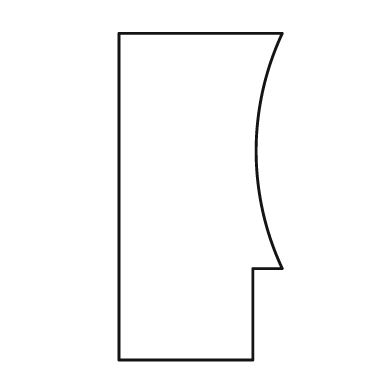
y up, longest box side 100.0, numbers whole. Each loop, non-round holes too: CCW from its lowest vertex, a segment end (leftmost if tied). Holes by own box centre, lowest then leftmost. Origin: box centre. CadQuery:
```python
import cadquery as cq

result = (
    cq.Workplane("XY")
    .moveTo(-25.0, -50.0)
    .lineTo(16.0, -50.0)
    .lineTo(16.0, -22.0)
    .lineTo(25.0, -22.0)
    .threePointArc((17.0, 14.0), (25.0, 50.0))
    .lineTo(-25.0, 50.0)
    .close()
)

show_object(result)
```